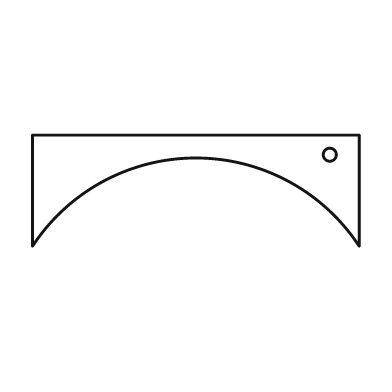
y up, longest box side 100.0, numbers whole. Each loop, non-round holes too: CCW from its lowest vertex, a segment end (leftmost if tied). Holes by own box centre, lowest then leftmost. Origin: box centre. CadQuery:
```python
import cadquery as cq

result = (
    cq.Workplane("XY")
    .moveTo(-50.0, -17.0)
    .threePointArc((0.0, 10.0), (50.0, -17.0))
    .lineTo(50.0, 17.0)
    .lineTo(-50.0, 17.0)
    .close()
    .moveTo(41.0, 11.0)
    .circle(2.0)
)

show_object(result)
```